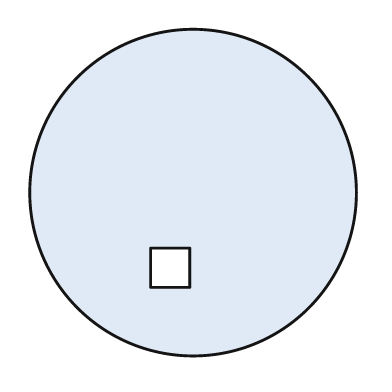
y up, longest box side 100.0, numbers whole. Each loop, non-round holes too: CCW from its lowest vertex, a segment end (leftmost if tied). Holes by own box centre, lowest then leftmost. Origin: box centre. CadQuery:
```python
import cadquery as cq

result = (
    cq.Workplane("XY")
    .moveTo(0.0, 0.0)
    .circle(50.0)
    .moveTo(-13.0, -29.0)
    .lineTo(-1.0, -29.0)
    .lineTo(-1.0, -17.0)
    .lineTo(-13.0, -17.0)
    .close()
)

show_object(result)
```